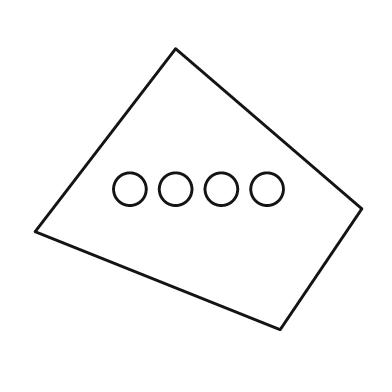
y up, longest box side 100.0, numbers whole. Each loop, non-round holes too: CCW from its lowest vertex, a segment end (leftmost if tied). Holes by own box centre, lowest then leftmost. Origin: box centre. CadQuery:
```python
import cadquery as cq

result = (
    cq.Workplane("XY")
    .moveTo(25.0, -43.0)
    .lineTo(50.0, -6.0)
    .lineTo(-7.0, 43.0)
    .lineTo(-50.0, -13.0)
    .close()
    .moveTo(-21.0, 0.0)
    .circle(5.0)
    .moveTo(-7.0, 0.0)
    .circle(5.0)
    .moveTo(7.0, 0.0)
    .circle(5.0)
    .moveTo(21.0, 0.0)
    .circle(5.0)
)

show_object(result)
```